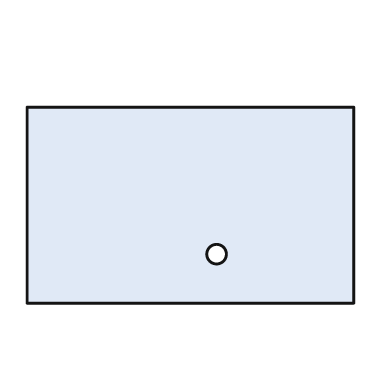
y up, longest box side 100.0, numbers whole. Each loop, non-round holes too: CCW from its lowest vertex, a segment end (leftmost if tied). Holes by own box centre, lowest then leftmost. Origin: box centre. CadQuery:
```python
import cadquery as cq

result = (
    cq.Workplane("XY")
    .moveTo(-50.0, -30.0)
    .lineTo(50.0, -30.0)
    .lineTo(50.0, 30.0)
    .lineTo(-50.0, 30.0)
    .close()
    .moveTo(8.0, -15.0)
    .circle(3.0)
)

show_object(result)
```